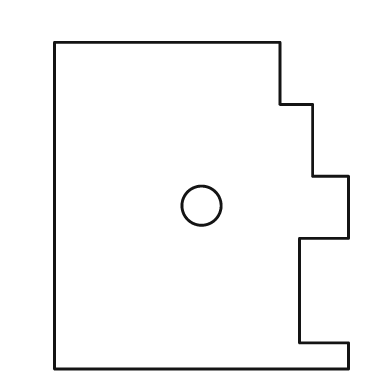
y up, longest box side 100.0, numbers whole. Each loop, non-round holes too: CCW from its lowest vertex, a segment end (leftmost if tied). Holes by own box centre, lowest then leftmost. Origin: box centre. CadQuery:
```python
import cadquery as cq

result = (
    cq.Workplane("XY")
    .moveTo(-45.0, -50.0)
    .lineTo(45.0, -50.0)
    .lineTo(45.0, -42.0)
    .lineTo(30.0, -42.0)
    .lineTo(30.0, -10.0)
    .lineTo(45.0, -10.0)
    .lineTo(45.0, 9.0)
    .lineTo(34.0, 9.0)
    .lineTo(34.0, 31.0)
    .lineTo(24.0, 31.0)
    .lineTo(24.0, 50.0)
    .lineTo(-45.0, 50.0)
    .close()
    .moveTo(0.0, 0.0)
    .circle(6.0)
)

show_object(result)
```